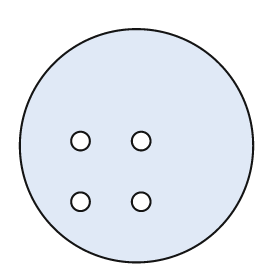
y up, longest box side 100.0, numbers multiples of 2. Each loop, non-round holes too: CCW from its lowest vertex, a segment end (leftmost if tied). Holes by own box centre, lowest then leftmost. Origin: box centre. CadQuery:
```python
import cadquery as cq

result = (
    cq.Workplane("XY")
    .moveTo(0.0, 0.0)
    .circle(50.0)
    .moveTo(-24.0, -24.0)
    .circle(4.0)
    .moveTo(2.0, -24.0)
    .circle(4.0)
    .moveTo(-24.0, 2.0)
    .circle(4.0)
    .moveTo(2.0, 2.0)
    .circle(4.0)
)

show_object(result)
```